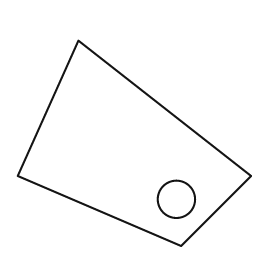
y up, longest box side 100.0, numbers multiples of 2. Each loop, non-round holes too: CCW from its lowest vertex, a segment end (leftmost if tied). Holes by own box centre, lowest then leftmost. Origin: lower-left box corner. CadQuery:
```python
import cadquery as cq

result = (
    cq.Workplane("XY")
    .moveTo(70.0, 0.0)
    .lineTo(100.0, 30.0)
    .lineTo(26.0, 88.0)
    .lineTo(0.0, 30.0)
    .close()
    .moveTo(68.0, 20.0)
    .circle(8.0)
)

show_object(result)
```